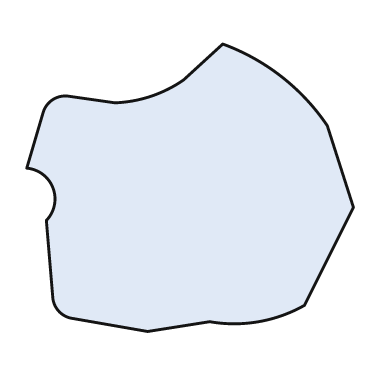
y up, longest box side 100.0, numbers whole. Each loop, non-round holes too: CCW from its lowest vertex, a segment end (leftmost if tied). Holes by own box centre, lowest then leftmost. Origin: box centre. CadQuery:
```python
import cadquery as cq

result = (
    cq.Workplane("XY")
    .moveTo(-13.0, -44.0)
    .lineTo(6.0, -41.0)
    .threePointArc((21.0, -41.0), (35.0, -36.0))
    .lineTo(50.0, -6.0)
    .lineTo(42.0, 19.0)
    .threePointArc((28.0, 34.0), (10.0, 44.0))
    .lineTo(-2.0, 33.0)
    .threePointArc((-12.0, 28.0), (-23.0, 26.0))
    .lineTo(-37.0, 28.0)
    .threePointArc((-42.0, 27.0), (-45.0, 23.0))
    .lineTo(-50.0, 6.0)
    .threePointArc((-42.0, 0.0), (-44.0, -10.0))
    .lineTo(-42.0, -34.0)
    .threePointArc((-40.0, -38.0), (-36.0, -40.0))
    .close()
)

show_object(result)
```